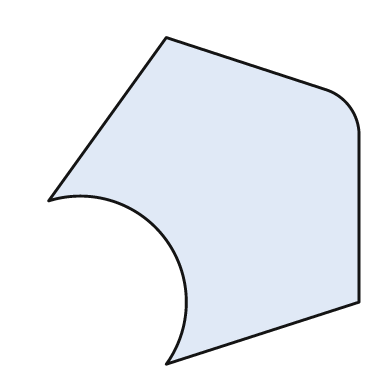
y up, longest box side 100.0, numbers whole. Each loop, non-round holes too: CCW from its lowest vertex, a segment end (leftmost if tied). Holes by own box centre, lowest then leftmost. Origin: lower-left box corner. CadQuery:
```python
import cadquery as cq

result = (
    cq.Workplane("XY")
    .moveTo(36.0, 0.0)
    .lineTo(95.0, 19.0)
    .lineTo(95.0, 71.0)
    .threePointArc((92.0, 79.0), (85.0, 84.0))
    .lineTo(36.0, 100.0)
    .lineTo(0.0, 50.0)
    .threePointArc((36.0, 38.0), (36.0, 0.0))
    .close()
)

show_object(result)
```